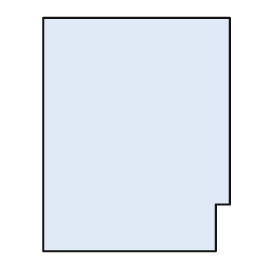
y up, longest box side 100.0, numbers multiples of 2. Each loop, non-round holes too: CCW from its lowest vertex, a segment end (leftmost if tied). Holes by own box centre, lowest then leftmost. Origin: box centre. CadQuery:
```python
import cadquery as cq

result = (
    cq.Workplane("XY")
    .moveTo(-40.0, -50.0)
    .lineTo(34.0, -50.0)
    .lineTo(34.0, -30.0)
    .lineTo(40.0, -30.0)
    .lineTo(40.0, 50.0)
    .lineTo(-40.0, 50.0)
    .close()
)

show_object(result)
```